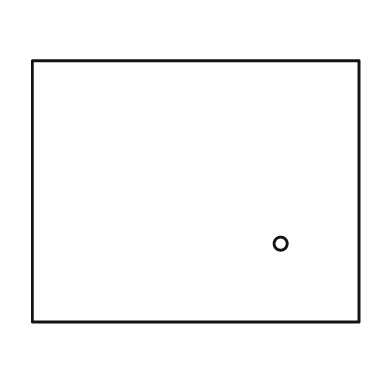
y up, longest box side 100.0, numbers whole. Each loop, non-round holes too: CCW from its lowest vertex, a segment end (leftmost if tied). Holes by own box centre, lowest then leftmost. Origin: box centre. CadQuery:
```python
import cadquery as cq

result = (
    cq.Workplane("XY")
    .moveTo(-50.0, -40.0)
    .lineTo(50.0, -40.0)
    .lineTo(50.0, 40.0)
    .lineTo(-50.0, 40.0)
    .close()
    .moveTo(26.0, -16.0)
    .circle(2.0)
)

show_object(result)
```